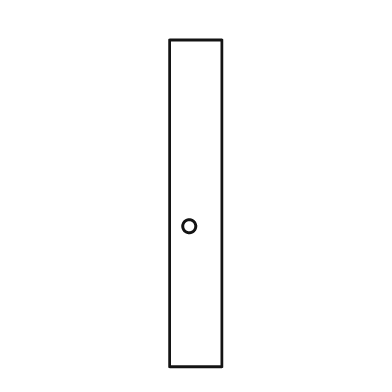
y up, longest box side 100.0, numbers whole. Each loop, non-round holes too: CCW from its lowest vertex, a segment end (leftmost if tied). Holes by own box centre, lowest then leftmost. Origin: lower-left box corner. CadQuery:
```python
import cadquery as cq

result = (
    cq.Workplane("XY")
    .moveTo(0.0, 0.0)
    .lineTo(16.0, 0.0)
    .lineTo(16.0, 100.0)
    .lineTo(0.0, 100.0)
    .close()
    .moveTo(6.0, 43.0)
    .circle(2.0)
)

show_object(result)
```